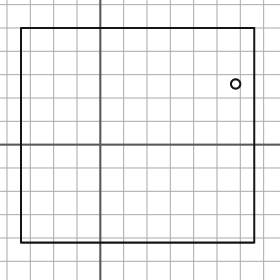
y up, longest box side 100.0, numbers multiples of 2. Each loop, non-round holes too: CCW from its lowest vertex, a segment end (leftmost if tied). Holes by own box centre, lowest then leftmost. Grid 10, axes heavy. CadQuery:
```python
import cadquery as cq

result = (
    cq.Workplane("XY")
    .moveTo(-34.0, -42.0)
    .lineTo(66.0, -42.0)
    .lineTo(66.0, 50.0)
    .lineTo(-34.0, 50.0)
    .close()
    .moveTo(58.0, 26.0)
    .circle(2.0)
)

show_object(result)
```